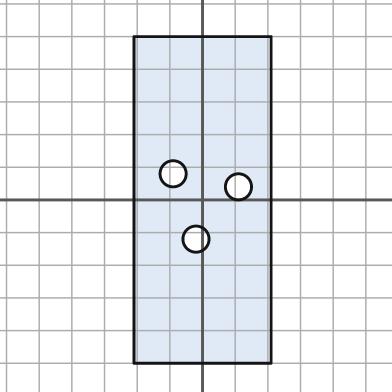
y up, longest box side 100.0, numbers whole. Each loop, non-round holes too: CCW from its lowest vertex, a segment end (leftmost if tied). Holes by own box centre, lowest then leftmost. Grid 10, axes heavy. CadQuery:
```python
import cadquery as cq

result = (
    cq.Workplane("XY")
    .moveTo(-21.0, -50.0)
    .lineTo(21.0, -50.0)
    .lineTo(21.0, 50.0)
    .lineTo(-21.0, 50.0)
    .close()
    .moveTo(-2.0, -12.0)
    .circle(4.0)
    .moveTo(11.0, 4.0)
    .circle(4.0)
    .moveTo(-9.0, 8.0)
    .circle(4.0)
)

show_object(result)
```